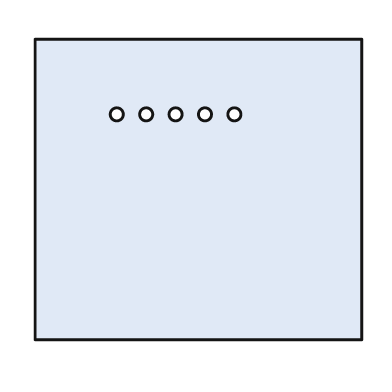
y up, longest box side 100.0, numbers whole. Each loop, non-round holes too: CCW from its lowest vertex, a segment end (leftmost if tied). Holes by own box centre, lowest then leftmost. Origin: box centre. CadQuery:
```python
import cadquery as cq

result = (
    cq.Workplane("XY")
    .moveTo(-50.0, -46.0)
    .lineTo(50.0, -46.0)
    .lineTo(50.0, 46.0)
    .lineTo(-50.0, 46.0)
    .close()
    .moveTo(-25.0, 23.0)
    .circle(2.0)
    .moveTo(-16.0, 23.0)
    .circle(2.0)
    .moveTo(-7.0, 23.0)
    .circle(2.0)
    .moveTo(2.0, 23.0)
    .circle(2.0)
    .moveTo(11.0, 23.0)
    .circle(2.0)
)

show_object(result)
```